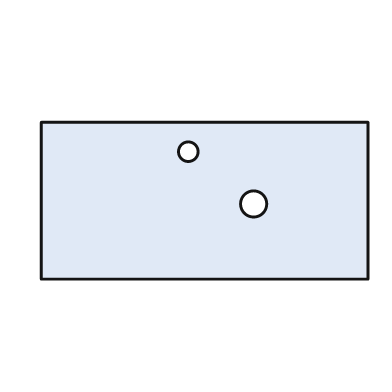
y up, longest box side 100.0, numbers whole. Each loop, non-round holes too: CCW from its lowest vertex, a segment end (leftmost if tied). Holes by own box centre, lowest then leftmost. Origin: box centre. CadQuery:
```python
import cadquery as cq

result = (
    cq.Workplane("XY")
    .moveTo(-50.0, -24.0)
    .lineTo(50.0, -24.0)
    .lineTo(50.0, 24.0)
    .lineTo(-50.0, 24.0)
    .close()
    .moveTo(15.0, -1.0)
    .circle(4.0)
    .moveTo(-5.0, 15.0)
    .circle(3.0)
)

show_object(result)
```